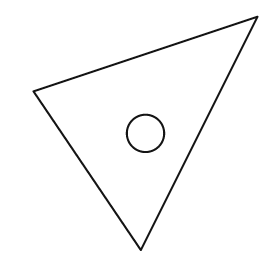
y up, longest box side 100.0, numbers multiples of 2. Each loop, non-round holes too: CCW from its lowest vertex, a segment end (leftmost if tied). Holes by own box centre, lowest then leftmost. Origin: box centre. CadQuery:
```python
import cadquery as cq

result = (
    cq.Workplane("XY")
    .moveTo(-2.0, -50.0)
    .lineTo(48.0, 50.0)
    .lineTo(-48.0, 18.0)
    .close()
    .moveTo(0.0, 0.0)
    .circle(8.0)
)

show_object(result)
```